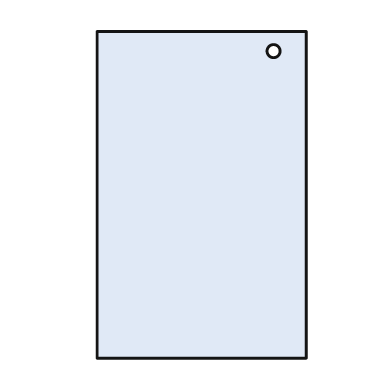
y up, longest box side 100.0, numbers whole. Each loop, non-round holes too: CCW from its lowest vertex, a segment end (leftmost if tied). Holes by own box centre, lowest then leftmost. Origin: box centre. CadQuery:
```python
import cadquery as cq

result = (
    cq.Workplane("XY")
    .moveTo(-32.0, -50.0)
    .lineTo(32.0, -50.0)
    .lineTo(32.0, 50.0)
    .lineTo(-32.0, 50.0)
    .close()
    .moveTo(22.0, 44.0)
    .circle(2.0)
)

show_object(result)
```